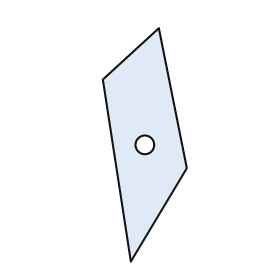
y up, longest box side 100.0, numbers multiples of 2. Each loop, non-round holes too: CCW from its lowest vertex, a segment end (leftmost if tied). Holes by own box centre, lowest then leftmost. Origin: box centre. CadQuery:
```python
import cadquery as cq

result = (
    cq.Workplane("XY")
    .moveTo(-6.0, -50.0)
    .lineTo(18.0, -10.0)
    .lineTo(6.0, 50.0)
    .lineTo(-18.0, 28.0)
    .close()
    .moveTo(0.0, 0.0)
    .circle(4.0)
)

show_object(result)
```